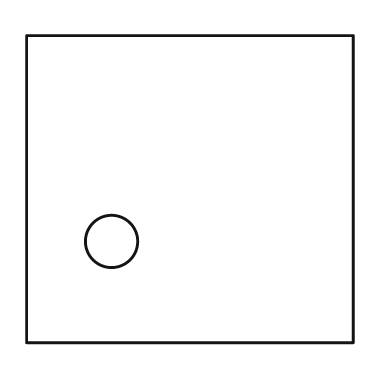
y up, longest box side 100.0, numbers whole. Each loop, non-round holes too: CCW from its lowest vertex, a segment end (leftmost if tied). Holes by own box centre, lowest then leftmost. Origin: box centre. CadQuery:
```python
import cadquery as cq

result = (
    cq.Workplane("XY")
    .moveTo(-50.0, -47.0)
    .lineTo(50.0, -47.0)
    .lineTo(50.0, 47.0)
    .lineTo(-50.0, 47.0)
    .close()
    .moveTo(-24.0, -16.0)
    .circle(8.0)
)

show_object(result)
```